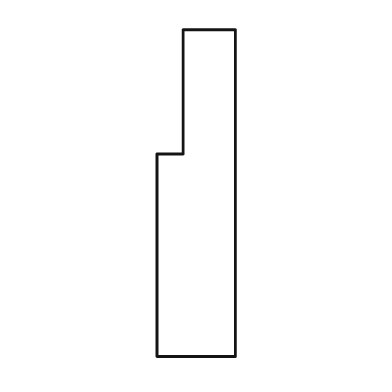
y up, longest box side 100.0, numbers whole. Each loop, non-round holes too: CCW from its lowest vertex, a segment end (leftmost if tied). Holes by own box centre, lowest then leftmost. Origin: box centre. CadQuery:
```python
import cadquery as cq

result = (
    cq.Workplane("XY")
    .moveTo(-12.0, -50.0)
    .lineTo(12.0, -50.0)
    .lineTo(12.0, 50.0)
    .lineTo(-4.0, 50.0)
    .lineTo(-4.0, 12.0)
    .lineTo(-12.0, 12.0)
    .close()
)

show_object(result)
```